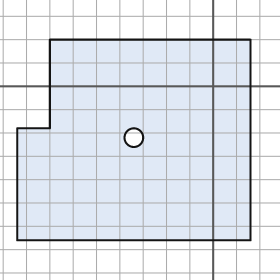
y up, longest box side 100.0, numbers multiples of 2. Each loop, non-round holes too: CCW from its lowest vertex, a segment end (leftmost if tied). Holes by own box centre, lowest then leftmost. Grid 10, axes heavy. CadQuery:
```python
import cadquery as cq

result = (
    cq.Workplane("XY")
    .moveTo(-84.0, -66.0)
    .lineTo(16.0, -66.0)
    .lineTo(16.0, 20.0)
    .lineTo(-70.0, 20.0)
    .lineTo(-70.0, -18.0)
    .lineTo(-84.0, -18.0)
    .close()
    .moveTo(-34.0, -22.0)
    .circle(4.0)
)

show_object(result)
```